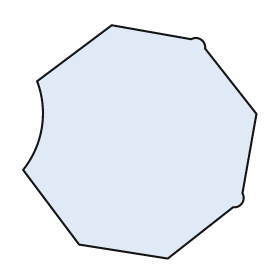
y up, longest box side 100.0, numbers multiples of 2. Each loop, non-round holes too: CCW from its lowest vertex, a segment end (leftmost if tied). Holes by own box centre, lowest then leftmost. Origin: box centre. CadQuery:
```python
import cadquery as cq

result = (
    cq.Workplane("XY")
    .moveTo(12.0, -50.0)
    .lineTo(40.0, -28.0)
    .threePointArc((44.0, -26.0), (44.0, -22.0))
    .lineTo(50.0, 12.0)
    .lineTo(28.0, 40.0)
    .threePointArc((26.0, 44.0), (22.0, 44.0))
    .lineTo(-12.0, 50.0)
    .lineTo(-44.0, 26.0)
    .threePointArc((-42.0, 6.0), (-50.0, -12.0))
    .lineTo(-26.0, -44.0)
    .close()
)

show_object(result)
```